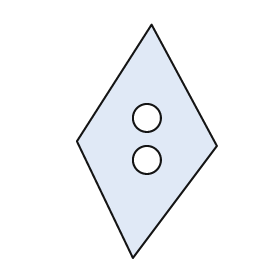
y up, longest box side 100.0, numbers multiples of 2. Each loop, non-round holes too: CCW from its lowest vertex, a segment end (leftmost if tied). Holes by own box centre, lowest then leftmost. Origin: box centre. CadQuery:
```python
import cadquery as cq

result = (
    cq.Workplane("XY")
    .moveTo(-6.0, -50.0)
    .lineTo(30.0, -2.0)
    .lineTo(2.0, 50.0)
    .lineTo(-30.0, 0.0)
    .close()
    .moveTo(0.0, -8.0)
    .circle(6.0)
    .moveTo(0.0, 10.0)
    .circle(6.0)
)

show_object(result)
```